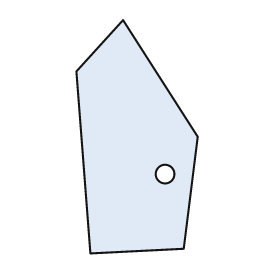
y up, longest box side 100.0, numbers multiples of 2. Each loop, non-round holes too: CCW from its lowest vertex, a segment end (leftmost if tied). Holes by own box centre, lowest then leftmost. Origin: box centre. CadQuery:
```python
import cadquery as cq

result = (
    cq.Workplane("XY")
    .moveTo(-20.0, -50.0)
    .lineTo(20.0, -48.0)
    .lineTo(26.0, 0.0)
    .lineTo(-6.0, 50.0)
    .lineTo(-26.0, 28.0)
    .close()
    .moveTo(12.0, -16.0)
    .circle(4.0)
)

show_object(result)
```